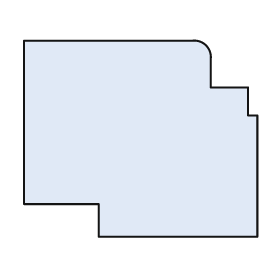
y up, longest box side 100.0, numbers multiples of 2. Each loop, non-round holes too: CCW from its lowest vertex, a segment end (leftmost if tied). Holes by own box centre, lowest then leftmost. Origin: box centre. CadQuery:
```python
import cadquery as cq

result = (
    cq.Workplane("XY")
    .moveTo(-18.0, -42.0)
    .lineTo(50.0, -42.0)
    .lineTo(50.0, 10.0)
    .lineTo(46.0, 10.0)
    .lineTo(46.0, 22.0)
    .lineTo(30.0, 22.0)
    .lineTo(30.0, 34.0)
    .threePointArc((28.0, 40.0), (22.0, 42.0))
    .lineTo(-50.0, 42.0)
    .lineTo(-50.0, -28.0)
    .lineTo(-18.0, -28.0)
    .close()
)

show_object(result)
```